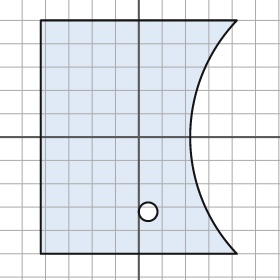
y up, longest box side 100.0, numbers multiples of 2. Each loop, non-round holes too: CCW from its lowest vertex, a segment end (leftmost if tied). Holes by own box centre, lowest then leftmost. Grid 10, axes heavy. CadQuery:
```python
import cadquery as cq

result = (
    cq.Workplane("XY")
    .moveTo(-42.0, -50.0)
    .lineTo(42.0, -50.0)
    .threePointArc((22.0, 0.0), (42.0, 50.0))
    .lineTo(-42.0, 50.0)
    .close()
    .moveTo(4.0, -32.0)
    .circle(4.0)
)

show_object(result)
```